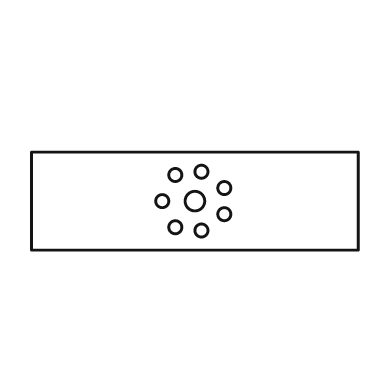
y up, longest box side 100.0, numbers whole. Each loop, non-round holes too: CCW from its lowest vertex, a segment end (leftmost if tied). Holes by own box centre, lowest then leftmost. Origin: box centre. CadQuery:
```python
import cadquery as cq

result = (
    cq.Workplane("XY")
    .moveTo(-50.0, -15.0)
    .lineTo(50.0, -15.0)
    .lineTo(50.0, 15.0)
    .lineTo(-50.0, 15.0)
    .close()
    .moveTo(2.0, -9.0)
    .circle(2.0)
    .moveTo(-6.0, -8.0)
    .circle(2.0)
    .moveTo(9.0, -4.0)
    .circle(2.0)
    .moveTo(-10.0, 0.0)
    .circle(2.0)
    .moveTo(0.0, 0.0)
    .circle(3.0)
    .moveTo(9.0, 4.0)
    .circle(2.0)
    .moveTo(-6.0, 8.0)
    .circle(2.0)
    .moveTo(2.0, 9.0)
    .circle(2.0)
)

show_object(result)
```